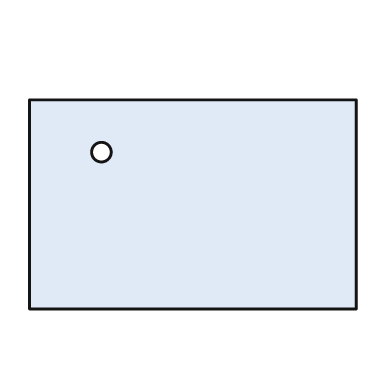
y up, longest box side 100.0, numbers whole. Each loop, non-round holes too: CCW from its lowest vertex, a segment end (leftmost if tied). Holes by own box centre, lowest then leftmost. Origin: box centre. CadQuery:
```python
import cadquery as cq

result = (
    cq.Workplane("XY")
    .moveTo(-50.0, -32.0)
    .lineTo(50.0, -32.0)
    .lineTo(50.0, 32.0)
    .lineTo(-50.0, 32.0)
    .close()
    .moveTo(-28.0, 16.0)
    .circle(3.0)
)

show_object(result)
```